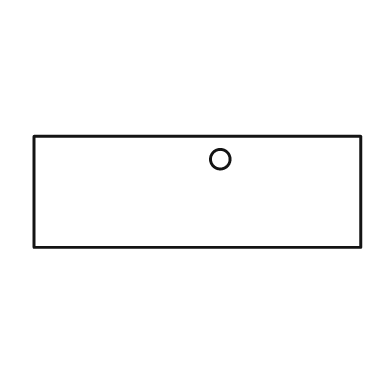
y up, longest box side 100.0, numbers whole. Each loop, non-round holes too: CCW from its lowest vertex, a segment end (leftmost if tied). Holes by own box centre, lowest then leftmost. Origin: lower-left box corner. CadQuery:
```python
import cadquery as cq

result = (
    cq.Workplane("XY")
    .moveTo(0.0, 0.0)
    .lineTo(100.0, 0.0)
    .lineTo(100.0, 34.0)
    .lineTo(0.0, 34.0)
    .close()
    .moveTo(57.0, 27.0)
    .circle(3.0)
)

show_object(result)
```